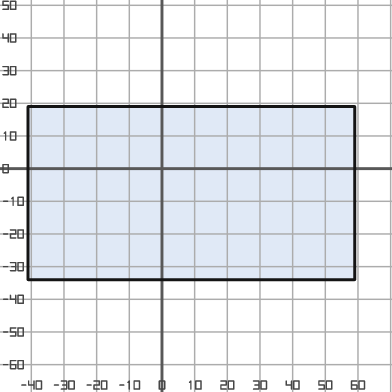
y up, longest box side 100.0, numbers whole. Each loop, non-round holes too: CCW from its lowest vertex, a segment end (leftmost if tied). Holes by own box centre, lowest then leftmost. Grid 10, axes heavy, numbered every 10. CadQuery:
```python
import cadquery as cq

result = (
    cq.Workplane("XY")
    .moveTo(-41.0, -34.0)
    .lineTo(59.0, -34.0)
    .lineTo(59.0, 19.0)
    .lineTo(-41.0, 19.0)
    .close()
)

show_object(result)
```